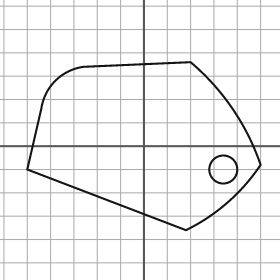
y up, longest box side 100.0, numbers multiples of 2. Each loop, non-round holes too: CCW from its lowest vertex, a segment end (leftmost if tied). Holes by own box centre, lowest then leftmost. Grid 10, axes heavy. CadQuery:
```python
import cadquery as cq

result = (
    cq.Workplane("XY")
    .moveTo(18.0, -36.0)
    .threePointArc((36.0, -24.0), (50.0, -8.0))
    .threePointArc((38.0, 16.0), (20.0, 36.0))
    .lineTo(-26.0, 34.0)
    .threePointArc((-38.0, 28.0), (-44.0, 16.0))
    .lineTo(-50.0, -10.0)
    .close()
    .moveTo(34.0, -10.0)
    .circle(6.0)
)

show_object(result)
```